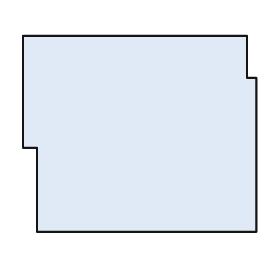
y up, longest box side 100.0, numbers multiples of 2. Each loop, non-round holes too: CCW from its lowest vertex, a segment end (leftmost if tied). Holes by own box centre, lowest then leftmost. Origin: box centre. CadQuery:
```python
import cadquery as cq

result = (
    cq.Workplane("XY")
    .moveTo(-44.0, -42.0)
    .lineTo(50.0, -42.0)
    .lineTo(50.0, 24.0)
    .lineTo(46.0, 24.0)
    .lineTo(46.0, 42.0)
    .lineTo(-50.0, 42.0)
    .lineTo(-50.0, -6.0)
    .lineTo(-44.0, -6.0)
    .close()
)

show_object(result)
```